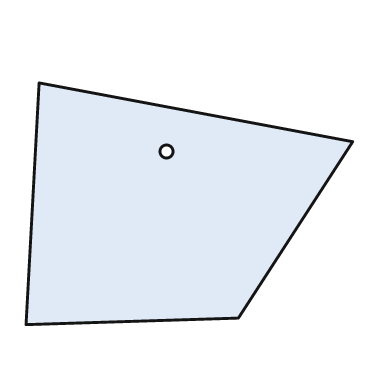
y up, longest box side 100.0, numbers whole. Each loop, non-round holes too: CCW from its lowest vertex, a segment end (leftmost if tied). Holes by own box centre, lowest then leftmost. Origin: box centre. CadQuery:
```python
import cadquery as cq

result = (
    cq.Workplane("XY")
    .moveTo(-50.0, -37.0)
    .lineTo(15.0, -35.0)
    .lineTo(50.0, 19.0)
    .lineTo(-46.0, 37.0)
    .close()
    .moveTo(-7.0, 16.0)
    .circle(2.0)
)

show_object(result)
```